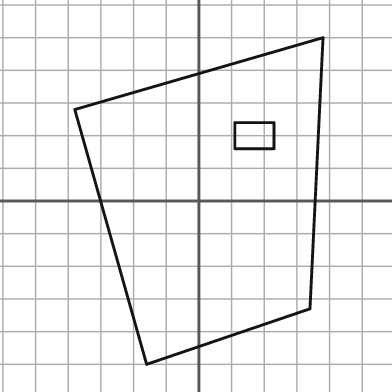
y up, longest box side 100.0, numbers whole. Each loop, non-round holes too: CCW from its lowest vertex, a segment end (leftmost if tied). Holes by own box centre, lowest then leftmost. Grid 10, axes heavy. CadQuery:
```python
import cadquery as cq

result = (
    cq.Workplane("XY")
    .moveTo(-16.0, -50.0)
    .lineTo(34.0, -33.0)
    .lineTo(38.0, 50.0)
    .lineTo(-38.0, 28.0)
    .close()
    .moveTo(11.0, 16.0)
    .lineTo(23.0, 16.0)
    .lineTo(23.0, 24.0)
    .lineTo(11.0, 24.0)
    .close()
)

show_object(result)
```